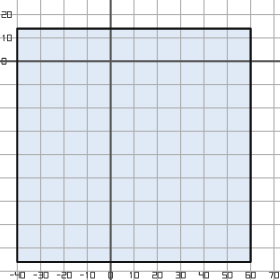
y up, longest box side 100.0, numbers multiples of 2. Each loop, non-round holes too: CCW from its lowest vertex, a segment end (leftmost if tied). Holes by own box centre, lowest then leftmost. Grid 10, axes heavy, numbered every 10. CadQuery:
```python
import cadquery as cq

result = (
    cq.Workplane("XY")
    .moveTo(-40.0, -86.0)
    .lineTo(60.0, -86.0)
    .lineTo(60.0, 14.0)
    .lineTo(-40.0, 14.0)
    .close()
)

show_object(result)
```